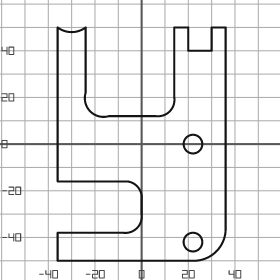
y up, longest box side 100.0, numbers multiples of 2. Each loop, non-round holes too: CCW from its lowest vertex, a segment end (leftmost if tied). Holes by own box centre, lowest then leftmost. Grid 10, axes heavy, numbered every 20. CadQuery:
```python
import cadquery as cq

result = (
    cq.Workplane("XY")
    .moveTo(-36.0, -50.0)
    .lineTo(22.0, -50.0)
    .threePointArc((32.0, -46.0), (36.0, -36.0))
    .lineTo(36.0, 50.0)
    .lineTo(30.0, 50.0)
    .lineTo(30.0, 40.0)
    .lineTo(20.0, 40.0)
    .lineTo(20.0, 50.0)
    .lineTo(14.0, 50.0)
    .lineTo(14.0, 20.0)
    .threePointArc((12.0, 14.0), (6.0, 12.0))
    .lineTo(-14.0, 12.0)
    .threePointArc((-22.0, 14.0), (-24.0, 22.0))
    .lineTo(-24.0, 50.0)
    .threePointArc((-30.0, 48.0), (-36.0, 50.0))
    .lineTo(-36.0, -16.0)
    .lineTo(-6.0, -16.0)
    .threePointArc((-2.0, -18.0), (0.0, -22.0))
    .lineTo(0.0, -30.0)
    .threePointArc((-2.0, -36.0), (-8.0, -38.0))
    .lineTo(-36.0, -38.0)
    .close()
    .moveTo(22.0, -42.0)
    .circle(4.0)
    .moveTo(22.0, 0.0)
    .circle(4.0)
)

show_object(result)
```